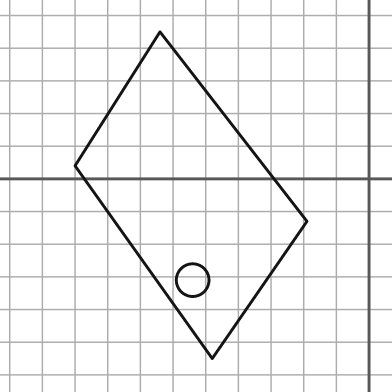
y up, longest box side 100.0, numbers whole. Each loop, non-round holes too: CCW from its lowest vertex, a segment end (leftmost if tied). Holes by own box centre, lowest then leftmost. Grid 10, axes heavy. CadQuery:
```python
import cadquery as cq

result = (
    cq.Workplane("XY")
    .moveTo(-48.0, -55.0)
    .lineTo(-19.0, -13.0)
    .lineTo(-64.0, 45.0)
    .lineTo(-90.0, 4.0)
    .close()
    .moveTo(-54.0, -31.0)
    .circle(5.0)
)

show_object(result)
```